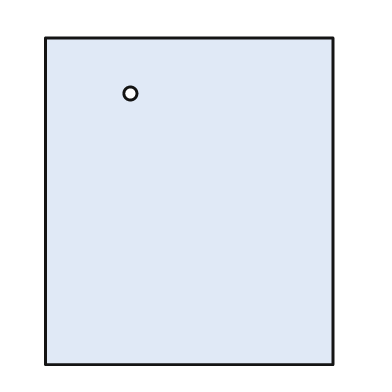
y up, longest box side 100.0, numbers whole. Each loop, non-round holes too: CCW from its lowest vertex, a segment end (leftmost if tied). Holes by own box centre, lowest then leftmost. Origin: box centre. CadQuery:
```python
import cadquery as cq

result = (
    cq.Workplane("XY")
    .moveTo(-44.0, -50.0)
    .lineTo(44.0, -50.0)
    .lineTo(44.0, 50.0)
    .lineTo(-44.0, 50.0)
    .close()
    .moveTo(-18.0, 33.0)
    .circle(2.0)
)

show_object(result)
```